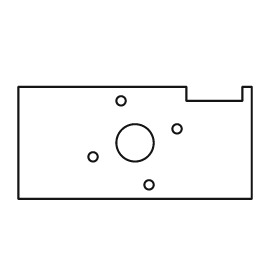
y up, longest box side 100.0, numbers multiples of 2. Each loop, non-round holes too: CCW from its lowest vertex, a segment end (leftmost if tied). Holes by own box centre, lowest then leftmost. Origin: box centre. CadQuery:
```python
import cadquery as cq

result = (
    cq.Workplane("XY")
    .moveTo(-50.0, -24.0)
    .lineTo(50.0, -24.0)
    .lineTo(50.0, 24.0)
    .lineTo(46.0, 24.0)
    .lineTo(46.0, 18.0)
    .lineTo(22.0, 18.0)
    .lineTo(22.0, 24.0)
    .lineTo(-50.0, 24.0)
    .close()
    .moveTo(6.0, -18.0)
    .circle(2.0)
    .moveTo(-18.0, -6.0)
    .circle(2.0)
    .moveTo(0.0, 0.0)
    .circle(8.0)
    .moveTo(18.0, 6.0)
    .circle(2.0)
    .moveTo(-6.0, 18.0)
    .circle(2.0)
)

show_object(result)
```